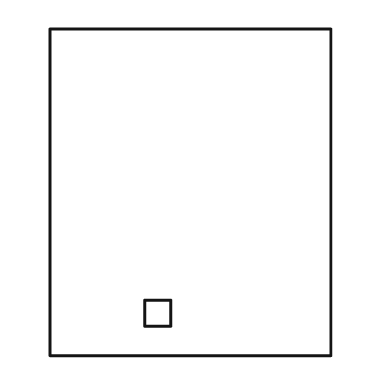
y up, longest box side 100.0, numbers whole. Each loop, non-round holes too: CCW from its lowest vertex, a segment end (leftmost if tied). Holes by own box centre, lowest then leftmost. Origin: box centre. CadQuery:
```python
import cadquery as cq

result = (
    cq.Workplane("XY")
    .moveTo(-43.0, -50.0)
    .lineTo(43.0, -50.0)
    .lineTo(43.0, 50.0)
    .lineTo(-43.0, 50.0)
    .close()
    .moveTo(-14.0, -41.0)
    .lineTo(-6.0, -41.0)
    .lineTo(-6.0, -33.0)
    .lineTo(-14.0, -33.0)
    .close()
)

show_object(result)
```